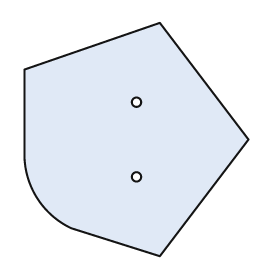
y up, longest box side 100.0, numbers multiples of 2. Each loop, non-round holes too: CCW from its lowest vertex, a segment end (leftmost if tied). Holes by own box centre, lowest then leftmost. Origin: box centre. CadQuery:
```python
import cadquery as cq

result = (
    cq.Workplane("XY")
    .moveTo(10.0, -50.0)
    .lineTo(48.0, 0.0)
    .lineTo(10.0, 50.0)
    .lineTo(-48.0, 30.0)
    .lineTo(-48.0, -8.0)
    .threePointArc((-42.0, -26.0), (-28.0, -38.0))
    .close()
    .moveTo(0.0, -16.0)
    .circle(2.0)
    .moveTo(0.0, 16.0)
    .circle(2.0)
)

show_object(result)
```